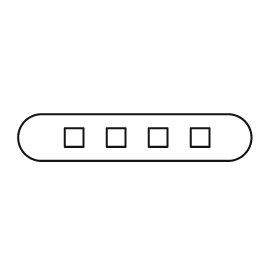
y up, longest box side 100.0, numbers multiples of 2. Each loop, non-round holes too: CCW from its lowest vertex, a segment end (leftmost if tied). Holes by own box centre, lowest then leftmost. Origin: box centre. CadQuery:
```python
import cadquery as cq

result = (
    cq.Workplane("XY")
    .moveTo(-40.0, -10.0)
    .lineTo(40.0, -10.0)
    .threePointArc((50.0, 0.0), (40.0, 10.0))
    .lineTo(-40.0, 10.0)
    .threePointArc((-50.0, 0.0), (-40.0, -10.0))
    .close()
    .moveTo(-30.0, -4.0)
    .lineTo(-22.0, -4.0)
    .lineTo(-22.0, 4.0)
    .lineTo(-30.0, 4.0)
    .close()
    .moveTo(-12.0, -4.0)
    .lineTo(-4.0, -4.0)
    .lineTo(-4.0, 4.0)
    .lineTo(-12.0, 4.0)
    .close()
    .moveTo(6.0, -4.0)
    .lineTo(14.0, -4.0)
    .lineTo(14.0, 4.0)
    .lineTo(6.0, 4.0)
    .close()
    .moveTo(24.0, -4.0)
    .lineTo(32.0, -4.0)
    .lineTo(32.0, 4.0)
    .lineTo(24.0, 4.0)
    .close()
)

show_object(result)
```